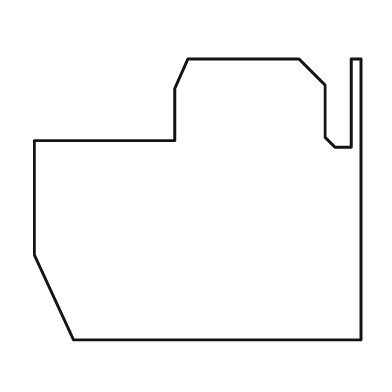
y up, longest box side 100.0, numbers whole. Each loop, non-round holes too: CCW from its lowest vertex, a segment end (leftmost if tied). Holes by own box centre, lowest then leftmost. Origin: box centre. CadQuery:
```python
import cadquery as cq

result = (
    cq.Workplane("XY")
    .moveTo(-38.0, -43.0)
    .lineTo(50.0, -43.0)
    .lineTo(50.0, 43.0)
    .lineTo(47.0, 43.0)
    .lineTo(47.0, 16.0)
    .lineTo(42.0, 16.0)
    .lineTo(39.0, 19.0)
    .lineTo(39.0, 35.0)
    .lineTo(31.0, 43.0)
    .lineTo(-3.0, 43.0)
    .lineTo(-7.0, 34.0)
    .lineTo(-7.0, 18.0)
    .lineTo(-50.0, 18.0)
    .lineTo(-50.0, -17.0)
    .close()
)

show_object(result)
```